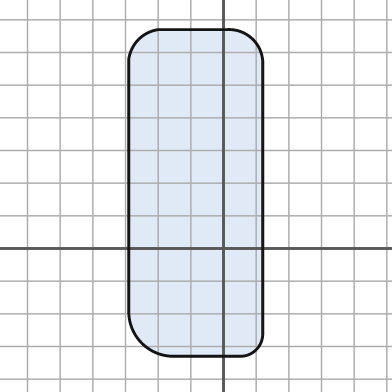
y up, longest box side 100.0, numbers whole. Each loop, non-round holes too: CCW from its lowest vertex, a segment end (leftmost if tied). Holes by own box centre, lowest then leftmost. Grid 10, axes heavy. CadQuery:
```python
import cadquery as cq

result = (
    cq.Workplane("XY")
    .moveTo(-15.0, -33.0)
    .lineTo(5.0, -33.0)
    .threePointArc((10.0, -31.0), (12.0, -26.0))
    .lineTo(12.0, 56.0)
    .threePointArc((9.0, 64.0), (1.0, 67.0))
    .lineTo(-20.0, 67.0)
    .threePointArc((-26.0, 64.0), (-29.0, 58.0))
    .lineTo(-29.0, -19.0)
    .threePointArc((-25.0, -29.0), (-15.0, -33.0))
    .close()
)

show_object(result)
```